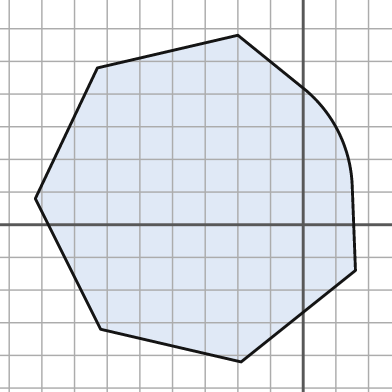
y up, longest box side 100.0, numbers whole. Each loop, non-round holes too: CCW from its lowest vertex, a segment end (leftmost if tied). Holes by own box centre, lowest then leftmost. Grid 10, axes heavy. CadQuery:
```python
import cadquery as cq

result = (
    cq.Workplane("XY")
    .moveTo(-19.0, -42.0)
    .lineTo(16.0, -14.0)
    .lineTo(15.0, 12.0)
    .threePointArc((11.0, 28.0), (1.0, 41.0))
    .lineTo(-20.0, 58.0)
    .lineTo(-63.0, 48.0)
    .lineTo(-82.0, 8.0)
    .lineTo(-62.0, -32.0)
    .close()
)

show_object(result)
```